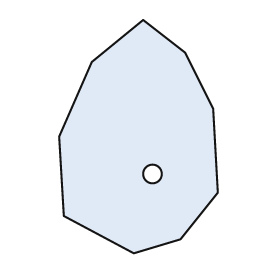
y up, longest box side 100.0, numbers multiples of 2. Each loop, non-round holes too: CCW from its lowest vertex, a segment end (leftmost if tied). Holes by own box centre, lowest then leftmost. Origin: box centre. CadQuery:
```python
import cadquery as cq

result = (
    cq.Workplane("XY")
    .moveTo(-2.0, -50.0)
    .lineTo(18.0, -44.0)
    .lineTo(34.0, -24.0)
    .lineTo(32.0, 12.0)
    .lineTo(20.0, 36.0)
    .lineTo(2.0, 50.0)
    .lineTo(-20.0, 32.0)
    .lineTo(-34.0, 0.0)
    .lineTo(-32.0, -34.0)
    .close()
    .moveTo(6.0, -16.0)
    .circle(4.0)
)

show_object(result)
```